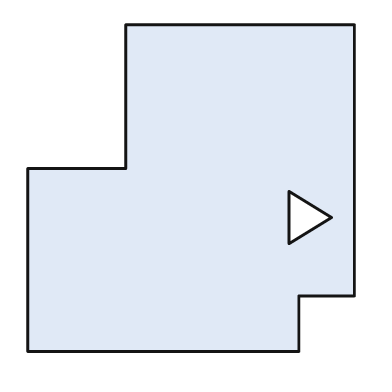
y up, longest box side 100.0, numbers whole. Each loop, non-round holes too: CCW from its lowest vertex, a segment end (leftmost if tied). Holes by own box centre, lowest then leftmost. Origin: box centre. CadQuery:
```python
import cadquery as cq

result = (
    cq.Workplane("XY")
    .moveTo(-50.0, -50.0)
    .lineTo(33.0, -50.0)
    .lineTo(33.0, -33.0)
    .lineTo(50.0, -33.0)
    .lineTo(50.0, 50.0)
    .lineTo(-20.0, 50.0)
    .lineTo(-20.0, 6.0)
    .lineTo(-50.0, 6.0)
    .close()
    .moveTo(30.0, -17.0)
    .lineTo(43.0, -9.0)
    .lineTo(30.0, -1.0)
    .close()
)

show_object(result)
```